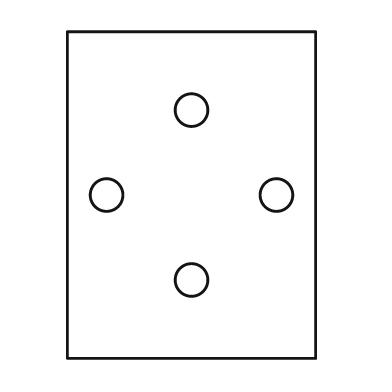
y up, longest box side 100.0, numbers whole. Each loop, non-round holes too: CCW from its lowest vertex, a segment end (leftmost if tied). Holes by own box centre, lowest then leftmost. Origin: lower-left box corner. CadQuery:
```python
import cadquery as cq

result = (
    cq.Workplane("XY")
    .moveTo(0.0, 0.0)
    .lineTo(76.0, 0.0)
    .lineTo(76.0, 100.0)
    .lineTo(0.0, 100.0)
    .close()
    .moveTo(38.0, 24.0)
    .circle(5.0)
    .moveTo(12.0, 50.0)
    .circle(5.0)
    .moveTo(64.0, 50.0)
    .circle(5.0)
    .moveTo(38.0, 76.0)
    .circle(5.0)
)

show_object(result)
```